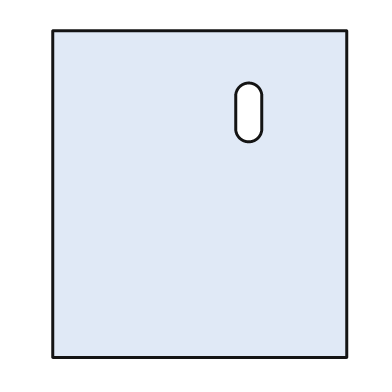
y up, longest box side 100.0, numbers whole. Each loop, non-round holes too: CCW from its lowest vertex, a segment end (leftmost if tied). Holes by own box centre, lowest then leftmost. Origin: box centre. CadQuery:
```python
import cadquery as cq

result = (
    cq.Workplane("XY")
    .moveTo(-45.0, -50.0)
    .lineTo(45.0, -50.0)
    .lineTo(45.0, 50.0)
    .lineTo(-45.0, 50.0)
    .close()
    .moveTo(11.0, 20.0)
    .threePointArc((15.0, 16.0), (19.0, 20.0))
    .lineTo(19.0, 30.0)
    .threePointArc((15.0, 34.0), (11.0, 30.0))
    .close()
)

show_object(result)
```